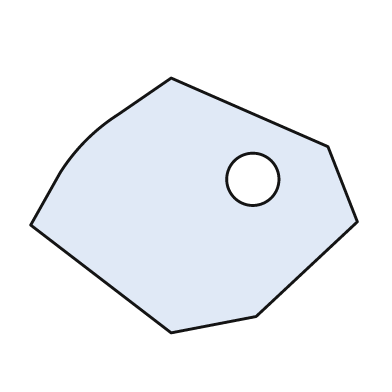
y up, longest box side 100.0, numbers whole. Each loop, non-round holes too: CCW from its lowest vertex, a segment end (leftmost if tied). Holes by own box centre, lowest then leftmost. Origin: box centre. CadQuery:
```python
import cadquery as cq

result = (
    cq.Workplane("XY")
    .moveTo(-7.0, -39.0)
    .lineTo(19.0, -34.0)
    .lineTo(50.0, -5.0)
    .lineTo(41.0, 18.0)
    .lineTo(-7.0, 39.0)
    .lineTo(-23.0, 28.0)
    .threePointArc((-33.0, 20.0), (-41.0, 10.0))
    .lineTo(-50.0, -6.0)
    .close()
    .moveTo(18.0, 8.0)
    .circle(8.0)
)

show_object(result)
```